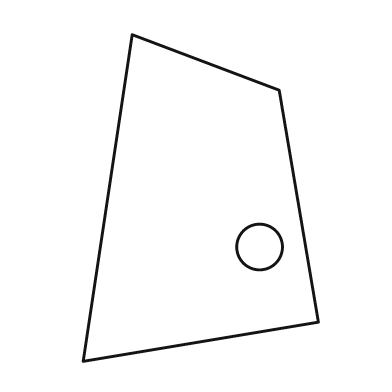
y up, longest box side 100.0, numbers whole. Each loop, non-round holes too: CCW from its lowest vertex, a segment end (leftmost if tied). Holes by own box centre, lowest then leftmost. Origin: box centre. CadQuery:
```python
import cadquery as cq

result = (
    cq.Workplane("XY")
    .moveTo(-36.0, -50.0)
    .lineTo(36.0, -38.0)
    .lineTo(24.0, 33.0)
    .lineTo(-21.0, 50.0)
    .close()
    .moveTo(18.0, -15.0)
    .circle(7.0)
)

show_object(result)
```